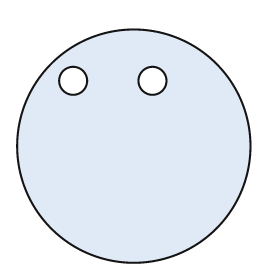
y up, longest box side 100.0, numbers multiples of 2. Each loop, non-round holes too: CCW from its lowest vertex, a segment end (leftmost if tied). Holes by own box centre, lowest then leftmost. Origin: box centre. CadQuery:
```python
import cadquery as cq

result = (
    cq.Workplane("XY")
    .moveTo(0.0, 0.0)
    .circle(50.0)
    .moveTo(-26.0, 28.0)
    .circle(6.0)
    .moveTo(8.0, 28.0)
    .circle(6.0)
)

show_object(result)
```